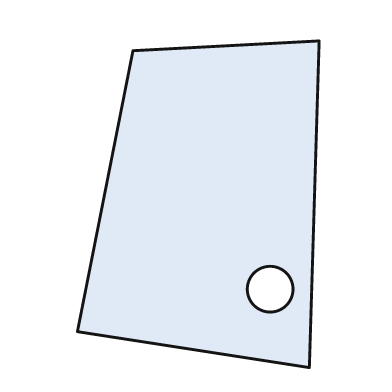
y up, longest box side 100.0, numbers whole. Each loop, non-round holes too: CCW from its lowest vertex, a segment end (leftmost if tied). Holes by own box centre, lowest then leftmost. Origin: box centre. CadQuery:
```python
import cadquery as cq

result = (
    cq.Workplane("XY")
    .moveTo(34.0, -50.0)
    .lineTo(37.0, 50.0)
    .lineTo(-20.0, 47.0)
    .lineTo(-37.0, -39.0)
    .close()
    .moveTo(22.0, -26.0)
    .circle(7.0)
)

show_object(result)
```